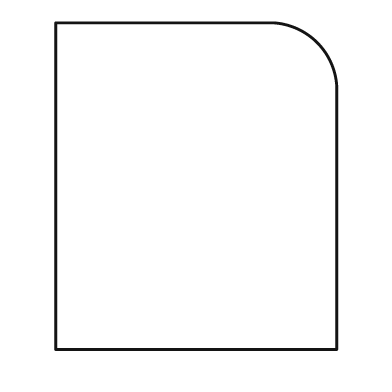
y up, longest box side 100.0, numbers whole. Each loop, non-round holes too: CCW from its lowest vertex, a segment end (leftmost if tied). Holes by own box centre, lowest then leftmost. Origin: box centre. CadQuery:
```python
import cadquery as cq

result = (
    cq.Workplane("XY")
    .moveTo(-43.0, -50.0)
    .lineTo(43.0, -50.0)
    .lineTo(43.0, 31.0)
    .threePointArc((37.0, 44.0), (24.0, 50.0))
    .lineTo(-43.0, 50.0)
    .close()
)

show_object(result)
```